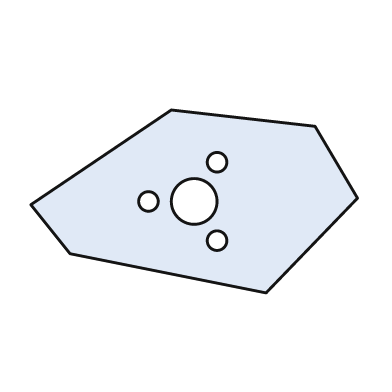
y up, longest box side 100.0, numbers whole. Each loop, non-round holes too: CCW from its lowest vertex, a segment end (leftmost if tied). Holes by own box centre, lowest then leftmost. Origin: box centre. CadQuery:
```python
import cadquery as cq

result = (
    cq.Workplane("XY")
    .moveTo(22.0, -28.0)
    .lineTo(50.0, 1.0)
    .lineTo(37.0, 23.0)
    .lineTo(-7.0, 28.0)
    .lineTo(-50.0, -1.0)
    .lineTo(-38.0, -16.0)
    .close()
    .moveTo(7.0, -12.0)
    .circle(3.0)
    .moveTo(-14.0, 0.0)
    .circle(3.0)
    .moveTo(0.0, 0.0)
    .circle(7.0)
    .moveTo(7.0, 12.0)
    .circle(3.0)
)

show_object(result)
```